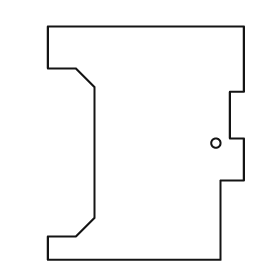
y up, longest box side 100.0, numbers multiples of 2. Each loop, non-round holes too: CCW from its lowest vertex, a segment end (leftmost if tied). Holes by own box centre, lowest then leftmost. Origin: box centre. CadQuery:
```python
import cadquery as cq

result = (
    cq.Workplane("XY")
    .moveTo(-42.0, -50.0)
    .lineTo(32.0, -50.0)
    .lineTo(32.0, -16.0)
    .lineTo(42.0, -16.0)
    .lineTo(42.0, 2.0)
    .lineTo(36.0, 2.0)
    .lineTo(36.0, 22.0)
    .lineTo(42.0, 22.0)
    .lineTo(42.0, 50.0)
    .lineTo(-42.0, 50.0)
    .lineTo(-42.0, 32.0)
    .lineTo(-30.0, 32.0)
    .lineTo(-22.0, 24.0)
    .lineTo(-22.0, -32.0)
    .lineTo(-30.0, -40.0)
    .lineTo(-42.0, -40.0)
    .close()
    .moveTo(30.0, 0.0)
    .circle(2.0)
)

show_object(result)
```